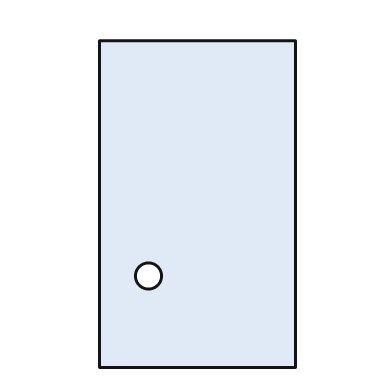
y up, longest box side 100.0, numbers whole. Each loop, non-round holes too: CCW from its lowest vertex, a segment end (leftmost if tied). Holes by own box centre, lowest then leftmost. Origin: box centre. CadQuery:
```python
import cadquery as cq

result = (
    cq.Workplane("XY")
    .moveTo(-30.0, -50.0)
    .lineTo(30.0, -50.0)
    .lineTo(30.0, 50.0)
    .lineTo(-30.0, 50.0)
    .close()
    .moveTo(-15.0, -22.0)
    .circle(4.0)
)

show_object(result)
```